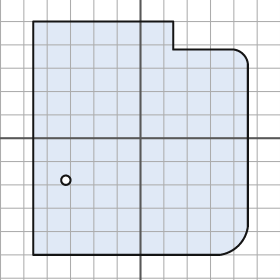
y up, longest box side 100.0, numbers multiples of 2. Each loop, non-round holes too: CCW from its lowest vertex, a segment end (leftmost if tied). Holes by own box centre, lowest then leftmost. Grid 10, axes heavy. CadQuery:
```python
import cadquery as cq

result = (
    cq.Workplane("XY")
    .moveTo(-46.0, -50.0)
    .lineTo(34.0, -50.0)
    .threePointArc((42.0, -46.0), (46.0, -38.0))
    .lineTo(46.0, 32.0)
    .threePointArc((44.0, 36.0), (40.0, 38.0))
    .lineTo(14.0, 38.0)
    .lineTo(14.0, 50.0)
    .lineTo(-46.0, 50.0)
    .close()
    .moveTo(-32.0, -18.0)
    .circle(2.0)
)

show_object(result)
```